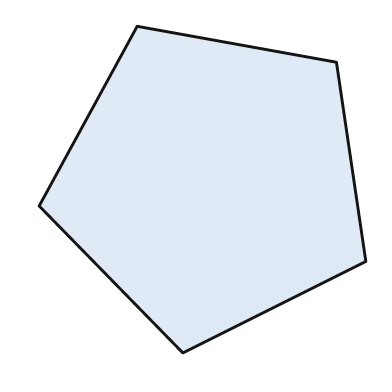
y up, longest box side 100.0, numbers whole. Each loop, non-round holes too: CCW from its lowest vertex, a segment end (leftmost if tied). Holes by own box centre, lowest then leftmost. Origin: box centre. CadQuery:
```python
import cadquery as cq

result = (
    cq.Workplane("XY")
    .moveTo(-6.0, -50.0)
    .lineTo(50.0, -22.0)
    .lineTo(41.0, 39.0)
    .lineTo(-20.0, 50.0)
    .lineTo(-50.0, -5.0)
    .close()
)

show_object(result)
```